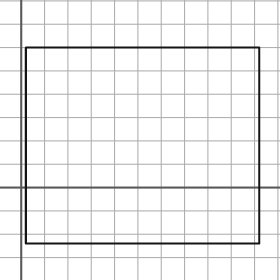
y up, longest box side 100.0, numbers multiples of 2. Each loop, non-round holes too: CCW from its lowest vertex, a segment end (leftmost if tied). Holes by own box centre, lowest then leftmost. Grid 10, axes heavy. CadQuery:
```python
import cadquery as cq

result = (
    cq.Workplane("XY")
    .moveTo(2.0, -24.0)
    .lineTo(102.0, -24.0)
    .lineTo(102.0, 60.0)
    .lineTo(2.0, 60.0)
    .close()
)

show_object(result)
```